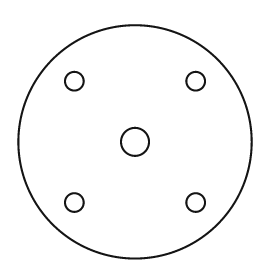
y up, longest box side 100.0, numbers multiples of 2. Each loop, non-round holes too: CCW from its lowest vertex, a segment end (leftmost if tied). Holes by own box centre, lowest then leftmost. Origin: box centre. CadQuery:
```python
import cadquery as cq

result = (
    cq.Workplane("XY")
    .moveTo(0.0, 0.0)
    .circle(50.0)
    .moveTo(-26.0, -26.0)
    .circle(4.0)
    .moveTo(26.0, -26.0)
    .circle(4.0)
    .moveTo(0.0, 0.0)
    .circle(6.0)
    .moveTo(-26.0, 26.0)
    .circle(4.0)
    .moveTo(26.0, 26.0)
    .circle(4.0)
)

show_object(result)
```